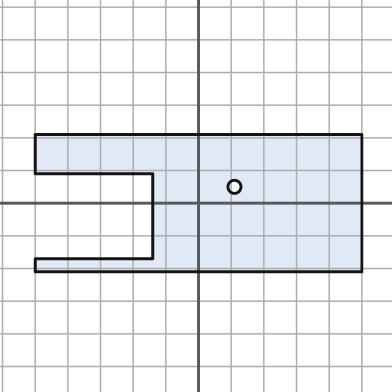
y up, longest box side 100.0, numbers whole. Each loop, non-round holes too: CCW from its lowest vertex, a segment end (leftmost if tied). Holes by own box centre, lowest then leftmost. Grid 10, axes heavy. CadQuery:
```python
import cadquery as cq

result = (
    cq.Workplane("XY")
    .moveTo(-50.0, -21.0)
    .lineTo(50.0, -21.0)
    .lineTo(50.0, 21.0)
    .lineTo(-50.0, 21.0)
    .lineTo(-50.0, 9.0)
    .lineTo(-14.0, 9.0)
    .lineTo(-14.0, -17.0)
    .lineTo(-50.0, -17.0)
    .close()
    .moveTo(11.0, 5.0)
    .circle(2.0)
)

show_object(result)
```